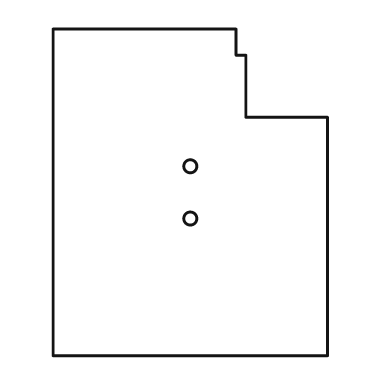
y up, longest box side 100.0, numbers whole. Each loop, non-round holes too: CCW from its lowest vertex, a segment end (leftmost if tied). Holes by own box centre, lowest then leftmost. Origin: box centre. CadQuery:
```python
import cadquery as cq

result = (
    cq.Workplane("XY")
    .moveTo(-42.0, -50.0)
    .lineTo(42.0, -50.0)
    .lineTo(42.0, 23.0)
    .lineTo(17.0, 23.0)
    .lineTo(17.0, 42.0)
    .lineTo(14.0, 42.0)
    .lineTo(14.0, 50.0)
    .lineTo(-42.0, 50.0)
    .close()
    .moveTo(0.0, -8.0)
    .circle(2.0)
    .moveTo(0.0, 8.0)
    .circle(2.0)
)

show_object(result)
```